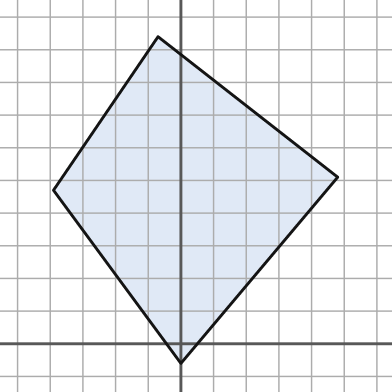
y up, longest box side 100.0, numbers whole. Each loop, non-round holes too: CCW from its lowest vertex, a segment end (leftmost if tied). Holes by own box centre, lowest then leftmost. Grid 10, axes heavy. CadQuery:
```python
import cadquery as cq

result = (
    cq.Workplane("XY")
    .moveTo(0.0, -6.0)
    .lineTo(48.0, 51.0)
    .lineTo(-7.0, 94.0)
    .lineTo(-39.0, 47.0)
    .close()
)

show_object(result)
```